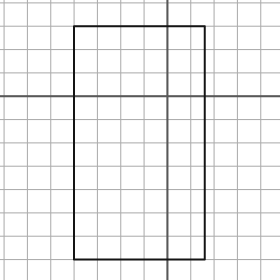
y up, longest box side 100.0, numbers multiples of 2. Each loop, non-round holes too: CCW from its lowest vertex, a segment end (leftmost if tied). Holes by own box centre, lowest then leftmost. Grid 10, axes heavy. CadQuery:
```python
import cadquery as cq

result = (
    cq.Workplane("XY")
    .moveTo(-40.0, -70.0)
    .lineTo(16.0, -70.0)
    .lineTo(16.0, 30.0)
    .lineTo(-40.0, 30.0)
    .close()
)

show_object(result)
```